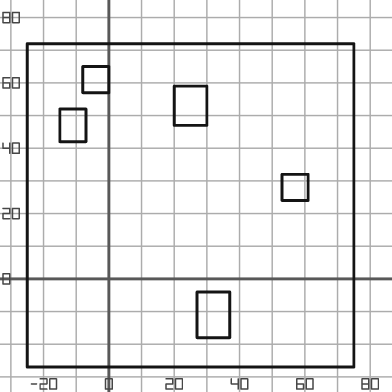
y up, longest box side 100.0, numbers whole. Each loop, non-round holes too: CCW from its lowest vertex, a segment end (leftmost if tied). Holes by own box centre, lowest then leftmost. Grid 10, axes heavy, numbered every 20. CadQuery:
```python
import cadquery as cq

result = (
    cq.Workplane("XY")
    .moveTo(-25.0, -27.0)
    .lineTo(75.0, -27.0)
    .lineTo(75.0, 72.0)
    .lineTo(-25.0, 72.0)
    .close()
    .moveTo(27.0, -18.0)
    .lineTo(37.0, -18.0)
    .lineTo(37.0, -4.0)
    .lineTo(27.0, -4.0)
    .close()
    .moveTo(53.0, 24.0)
    .lineTo(61.0, 24.0)
    .lineTo(61.0, 32.0)
    .lineTo(53.0, 32.0)
    .close()
    .moveTo(-15.0, 42.0)
    .lineTo(-7.0, 42.0)
    .lineTo(-7.0, 52.0)
    .lineTo(-15.0, 52.0)
    .close()
    .moveTo(20.0, 47.0)
    .lineTo(30.0, 47.0)
    .lineTo(30.0, 59.0)
    .lineTo(20.0, 59.0)
    .close()
    .moveTo(-8.0, 57.0)
    .lineTo(0.0, 57.0)
    .lineTo(0.0, 65.0)
    .lineTo(-8.0, 65.0)
    .close()
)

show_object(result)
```